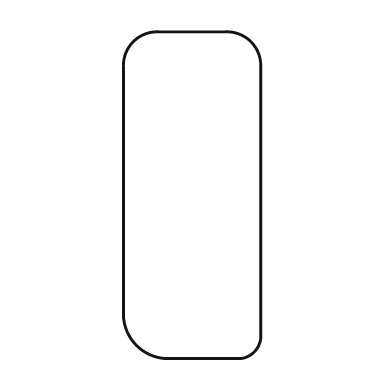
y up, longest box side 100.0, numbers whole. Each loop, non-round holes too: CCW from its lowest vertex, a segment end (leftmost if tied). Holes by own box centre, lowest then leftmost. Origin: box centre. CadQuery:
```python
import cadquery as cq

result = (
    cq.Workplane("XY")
    .moveTo(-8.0, -50.0)
    .lineTo(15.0, -50.0)
    .threePointArc((19.0, -48.0), (21.0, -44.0))
    .lineTo(21.0, 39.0)
    .threePointArc((18.0, 47.0), (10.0, 50.0))
    .lineTo(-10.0, 50.0)
    .threePointArc((-18.0, 47.0), (-21.0, 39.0))
    .lineTo(-21.0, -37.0)
    .threePointArc((-17.0, -46.0), (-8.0, -50.0))
    .close()
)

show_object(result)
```